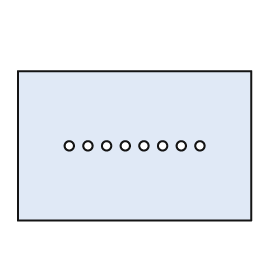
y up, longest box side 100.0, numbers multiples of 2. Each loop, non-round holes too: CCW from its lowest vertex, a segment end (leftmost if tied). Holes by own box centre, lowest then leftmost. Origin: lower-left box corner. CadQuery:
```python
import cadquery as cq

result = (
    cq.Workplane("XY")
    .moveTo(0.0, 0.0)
    .lineTo(100.0, 0.0)
    .lineTo(100.0, 64.0)
    .lineTo(0.0, 64.0)
    .close()
    .moveTo(22.0, 32.0)
    .circle(2.0)
    .moveTo(30.0, 32.0)
    .circle(2.0)
    .moveTo(38.0, 32.0)
    .circle(2.0)
    .moveTo(46.0, 32.0)
    .circle(2.0)
    .moveTo(54.0, 32.0)
    .circle(2.0)
    .moveTo(62.0, 32.0)
    .circle(2.0)
    .moveTo(70.0, 32.0)
    .circle(2.0)
    .moveTo(78.0, 32.0)
    .circle(2.0)
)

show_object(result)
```